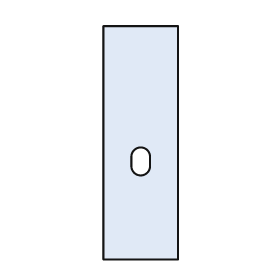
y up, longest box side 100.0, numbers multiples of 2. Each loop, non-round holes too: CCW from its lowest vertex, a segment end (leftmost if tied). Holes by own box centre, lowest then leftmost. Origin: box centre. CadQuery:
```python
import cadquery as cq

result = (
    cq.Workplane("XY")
    .moveTo(-16.0, -50.0)
    .lineTo(16.0, -50.0)
    .lineTo(16.0, 50.0)
    .lineTo(-16.0, 50.0)
    .close()
    .moveTo(-4.0, -10.0)
    .threePointArc((0.0, -14.0), (4.0, -10.0))
    .lineTo(4.0, -6.0)
    .threePointArc((0.0, -2.0), (-4.0, -6.0))
    .close()
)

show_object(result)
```